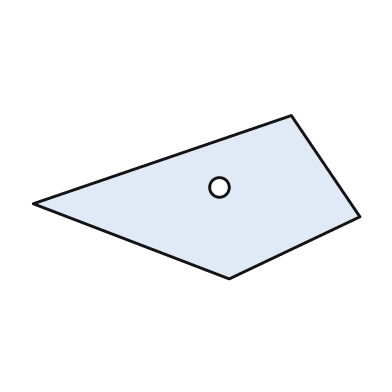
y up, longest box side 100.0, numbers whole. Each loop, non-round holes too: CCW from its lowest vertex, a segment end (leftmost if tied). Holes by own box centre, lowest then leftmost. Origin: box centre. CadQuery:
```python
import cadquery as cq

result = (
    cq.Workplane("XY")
    .moveTo(10.0, -25.0)
    .lineTo(50.0, -6.0)
    .lineTo(29.0, 25.0)
    .lineTo(-50.0, -2.0)
    .close()
    .moveTo(7.0, 3.0)
    .circle(3.0)
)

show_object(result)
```